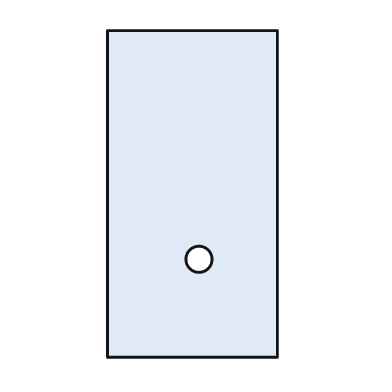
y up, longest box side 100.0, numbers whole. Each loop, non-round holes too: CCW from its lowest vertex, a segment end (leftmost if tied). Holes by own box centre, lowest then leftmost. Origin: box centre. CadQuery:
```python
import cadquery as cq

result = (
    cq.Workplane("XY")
    .moveTo(-26.0, -50.0)
    .lineTo(26.0, -50.0)
    .lineTo(26.0, 50.0)
    .lineTo(-26.0, 50.0)
    .close()
    .moveTo(2.0, -20.0)
    .circle(4.0)
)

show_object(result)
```